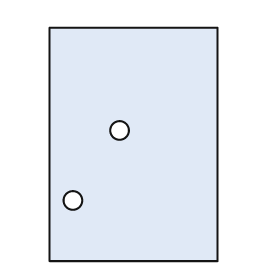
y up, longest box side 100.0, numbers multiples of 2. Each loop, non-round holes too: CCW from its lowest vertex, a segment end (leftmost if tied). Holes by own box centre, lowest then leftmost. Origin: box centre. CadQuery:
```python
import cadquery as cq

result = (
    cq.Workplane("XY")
    .moveTo(-36.0, -50.0)
    .lineTo(36.0, -50.0)
    .lineTo(36.0, 50.0)
    .lineTo(-36.0, 50.0)
    .close()
    .moveTo(-26.0, -24.0)
    .circle(4.0)
    .moveTo(-6.0, 6.0)
    .circle(4.0)
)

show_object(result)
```